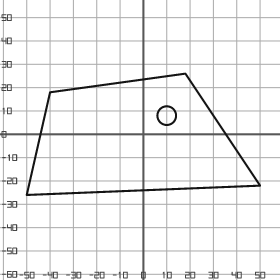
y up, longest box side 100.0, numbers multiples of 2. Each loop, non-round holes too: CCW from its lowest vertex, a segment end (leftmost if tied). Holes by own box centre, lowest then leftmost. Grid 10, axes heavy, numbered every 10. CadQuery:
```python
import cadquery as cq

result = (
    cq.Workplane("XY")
    .moveTo(-50.0, -26.0)
    .lineTo(50.0, -22.0)
    .lineTo(18.0, 26.0)
    .lineTo(-40.0, 18.0)
    .close()
    .moveTo(10.0, 8.0)
    .circle(4.0)
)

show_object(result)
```